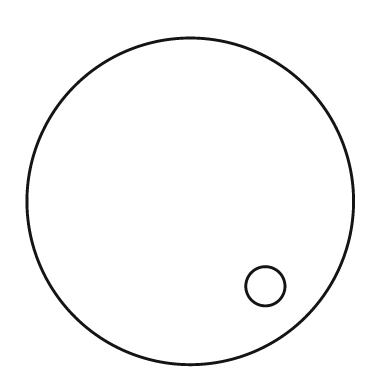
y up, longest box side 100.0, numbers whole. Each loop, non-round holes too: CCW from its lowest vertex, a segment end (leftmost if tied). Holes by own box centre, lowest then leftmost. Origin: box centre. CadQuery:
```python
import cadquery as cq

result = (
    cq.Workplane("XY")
    .moveTo(0.0, 0.0)
    .circle(50.0)
    .moveTo(23.0, -26.0)
    .circle(6.0)
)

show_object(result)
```